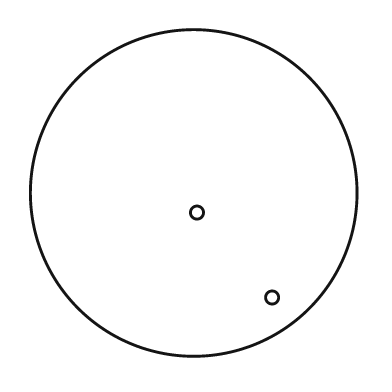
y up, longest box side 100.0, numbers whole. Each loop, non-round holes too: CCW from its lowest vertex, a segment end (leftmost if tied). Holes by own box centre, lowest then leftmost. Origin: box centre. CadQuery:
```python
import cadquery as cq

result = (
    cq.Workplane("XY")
    .moveTo(0.0, 0.0)
    .circle(50.0)
    .moveTo(24.0, -32.0)
    .circle(2.0)
    .moveTo(1.0, -6.0)
    .circle(2.0)
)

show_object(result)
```